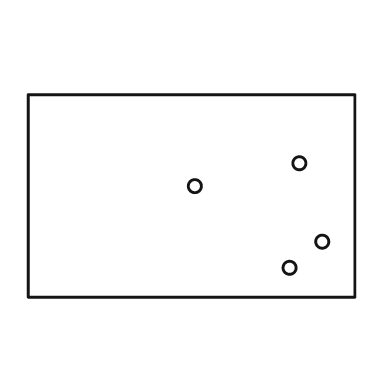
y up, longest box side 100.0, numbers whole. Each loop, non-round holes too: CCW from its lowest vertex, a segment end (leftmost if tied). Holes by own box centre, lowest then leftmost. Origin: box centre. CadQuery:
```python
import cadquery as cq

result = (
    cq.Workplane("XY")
    .moveTo(-50.0, -31.0)
    .lineTo(50.0, -31.0)
    .lineTo(50.0, 31.0)
    .lineTo(-50.0, 31.0)
    .close()
    .moveTo(30.0, -22.0)
    .circle(2.0)
    .moveTo(40.0, -14.0)
    .circle(2.0)
    .moveTo(1.0, 3.0)
    .circle(2.0)
    .moveTo(33.0, 10.0)
    .circle(2.0)
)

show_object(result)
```